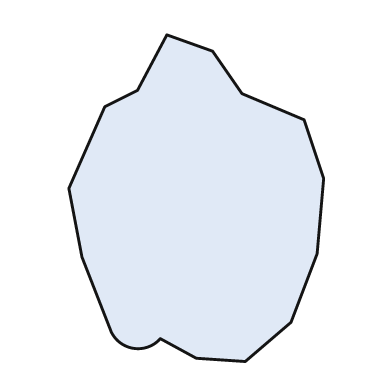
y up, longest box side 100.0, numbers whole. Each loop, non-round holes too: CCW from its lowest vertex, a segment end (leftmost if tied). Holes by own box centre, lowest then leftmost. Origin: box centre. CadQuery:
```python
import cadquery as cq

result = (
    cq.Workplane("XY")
    .moveTo(15.0, -50.0)
    .lineTo(29.0, -38.0)
    .lineTo(37.0, -17.0)
    .lineTo(39.0, 6.0)
    .lineTo(33.0, 24.0)
    .lineTo(14.0, 32.0)
    .lineTo(5.0, 45.0)
    .lineTo(-9.0, 50.0)
    .lineTo(-18.0, 33.0)
    .lineTo(-28.0, 28.0)
    .lineTo(-39.0, 3.0)
    .lineTo(-35.0, -18.0)
    .lineTo(-26.0, -41.0)
    .threePointArc((-19.0, -46.0), (-11.0, -43.0))
    .lineTo(0.0, -49.0)
    .close()
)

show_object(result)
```